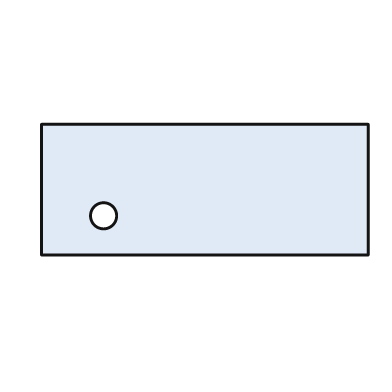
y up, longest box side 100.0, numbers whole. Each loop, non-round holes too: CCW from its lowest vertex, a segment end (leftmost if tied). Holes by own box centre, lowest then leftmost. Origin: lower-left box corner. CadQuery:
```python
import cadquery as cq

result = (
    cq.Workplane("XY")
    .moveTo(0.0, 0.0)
    .lineTo(100.0, 0.0)
    .lineTo(100.0, 40.0)
    .lineTo(0.0, 40.0)
    .close()
    .moveTo(19.0, 12.0)
    .circle(4.0)
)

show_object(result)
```